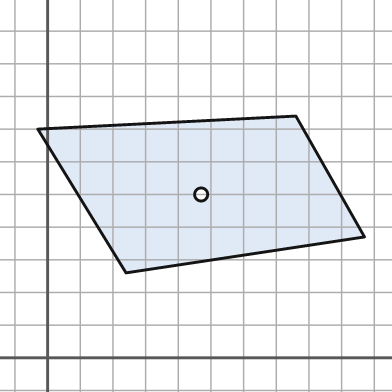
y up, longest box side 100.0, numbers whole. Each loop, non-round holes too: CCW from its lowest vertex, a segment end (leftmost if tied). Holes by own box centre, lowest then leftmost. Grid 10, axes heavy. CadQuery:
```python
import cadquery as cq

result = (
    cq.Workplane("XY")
    .moveTo(24.0, 26.0)
    .lineTo(97.0, 37.0)
    .lineTo(76.0, 74.0)
    .lineTo(-3.0, 70.0)
    .close()
    .moveTo(47.0, 50.0)
    .circle(2.0)
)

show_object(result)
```